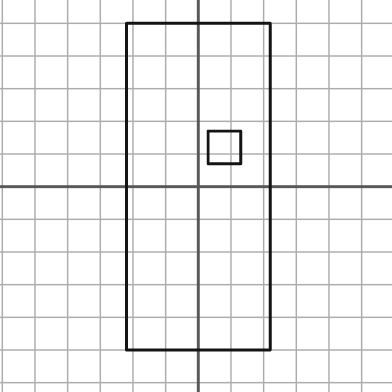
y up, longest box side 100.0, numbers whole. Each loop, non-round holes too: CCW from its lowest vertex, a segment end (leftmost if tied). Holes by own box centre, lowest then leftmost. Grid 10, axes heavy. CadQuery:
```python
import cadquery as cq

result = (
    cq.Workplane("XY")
    .moveTo(-22.0, -50.0)
    .lineTo(22.0, -50.0)
    .lineTo(22.0, 50.0)
    .lineTo(-22.0, 50.0)
    .close()
    .moveTo(3.0, 7.0)
    .lineTo(13.0, 7.0)
    .lineTo(13.0, 17.0)
    .lineTo(3.0, 17.0)
    .close()
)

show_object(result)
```